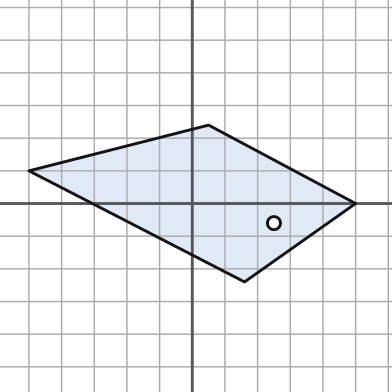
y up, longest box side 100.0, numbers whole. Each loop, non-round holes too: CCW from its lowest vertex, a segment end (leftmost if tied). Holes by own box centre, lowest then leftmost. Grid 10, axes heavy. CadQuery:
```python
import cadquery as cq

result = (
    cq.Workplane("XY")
    .moveTo(16.0, -24.0)
    .lineTo(50.0, 0.0)
    .lineTo(5.0, 24.0)
    .lineTo(-50.0, 10.0)
    .close()
    .moveTo(25.0, -6.0)
    .circle(2.0)
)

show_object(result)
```